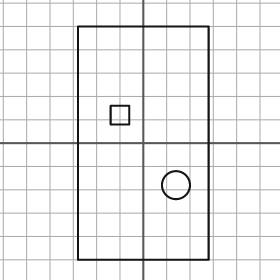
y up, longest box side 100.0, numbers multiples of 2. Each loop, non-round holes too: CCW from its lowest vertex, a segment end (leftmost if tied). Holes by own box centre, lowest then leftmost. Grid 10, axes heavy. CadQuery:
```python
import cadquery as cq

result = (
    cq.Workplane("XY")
    .moveTo(-28.0, -50.0)
    .lineTo(28.0, -50.0)
    .lineTo(28.0, 50.0)
    .lineTo(-28.0, 50.0)
    .close()
    .moveTo(14.0, -18.0)
    .circle(6.0)
    .moveTo(-14.0, 8.0)
    .lineTo(-6.0, 8.0)
    .lineTo(-6.0, 16.0)
    .lineTo(-14.0, 16.0)
    .close()
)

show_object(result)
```